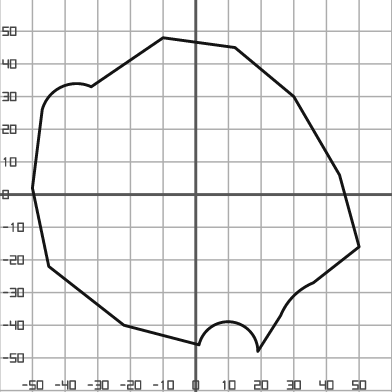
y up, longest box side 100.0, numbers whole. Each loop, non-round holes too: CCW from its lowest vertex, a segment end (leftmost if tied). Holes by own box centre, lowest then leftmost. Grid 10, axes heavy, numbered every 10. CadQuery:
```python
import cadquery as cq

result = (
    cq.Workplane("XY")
    .moveTo(19.0, -48.0)
    .lineTo(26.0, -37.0)
    .threePointArc((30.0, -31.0), (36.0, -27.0))
    .lineTo(50.0, -16.0)
    .lineTo(44.0, 6.0)
    .lineTo(30.0, 30.0)
    .lineTo(12.0, 45.0)
    .lineTo(-10.0, 48.0)
    .lineTo(-32.0, 33.0)
    .threePointArc((-41.0, 33.0), (-47.0, 26.0))
    .lineTo(-50.0, 2.0)
    .lineTo(-45.0, -22.0)
    .lineTo(-22.0, -40.0)
    .lineTo(1.0, -46.0)
    .threePointArc((11.0, -39.0), (19.0, -48.0))
    .close()
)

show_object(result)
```